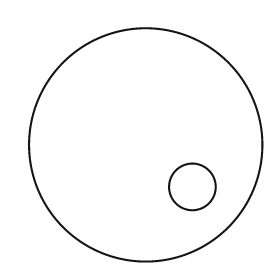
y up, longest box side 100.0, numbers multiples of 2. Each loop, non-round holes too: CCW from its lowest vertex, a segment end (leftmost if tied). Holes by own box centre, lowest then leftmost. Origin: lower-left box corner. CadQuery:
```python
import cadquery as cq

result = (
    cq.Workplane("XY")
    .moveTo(50.0, 50.0)
    .circle(50.0)
    .moveTo(70.0, 32.0)
    .circle(10.0)
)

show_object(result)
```